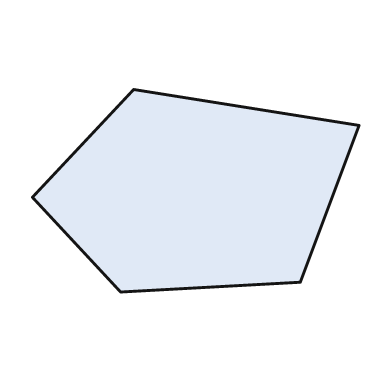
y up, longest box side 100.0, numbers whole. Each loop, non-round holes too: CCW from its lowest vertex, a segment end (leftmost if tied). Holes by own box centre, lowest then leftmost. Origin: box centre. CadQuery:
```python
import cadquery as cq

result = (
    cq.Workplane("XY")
    .moveTo(-23.0, -31.0)
    .lineTo(32.0, -28.0)
    .lineTo(50.0, 20.0)
    .lineTo(-19.0, 31.0)
    .lineTo(-50.0, -2.0)
    .close()
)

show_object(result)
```